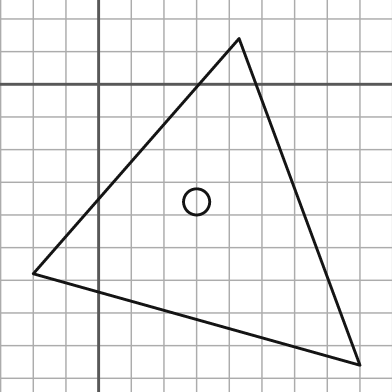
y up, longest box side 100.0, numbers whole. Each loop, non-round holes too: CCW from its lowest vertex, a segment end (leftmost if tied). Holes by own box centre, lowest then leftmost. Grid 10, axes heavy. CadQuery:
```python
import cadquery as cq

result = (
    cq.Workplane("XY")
    .moveTo(80.0, -86.0)
    .lineTo(43.0, 14.0)
    .lineTo(-20.0, -58.0)
    .close()
    .moveTo(30.0, -36.0)
    .circle(4.0)
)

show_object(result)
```